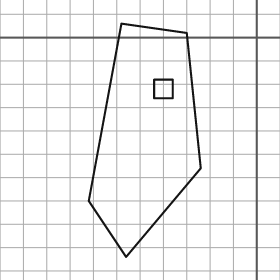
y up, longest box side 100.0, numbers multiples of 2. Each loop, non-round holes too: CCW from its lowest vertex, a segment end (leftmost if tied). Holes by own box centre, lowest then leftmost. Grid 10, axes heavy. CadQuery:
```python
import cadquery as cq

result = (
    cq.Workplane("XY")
    .moveTo(-56.0, -94.0)
    .lineTo(-24.0, -56.0)
    .lineTo(-30.0, 2.0)
    .lineTo(-58.0, 6.0)
    .lineTo(-72.0, -70.0)
    .close()
    .moveTo(-44.0, -26.0)
    .lineTo(-36.0, -26.0)
    .lineTo(-36.0, -18.0)
    .lineTo(-44.0, -18.0)
    .close()
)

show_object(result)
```